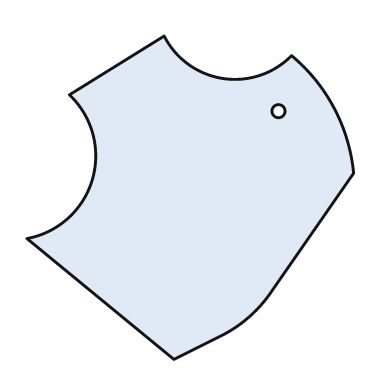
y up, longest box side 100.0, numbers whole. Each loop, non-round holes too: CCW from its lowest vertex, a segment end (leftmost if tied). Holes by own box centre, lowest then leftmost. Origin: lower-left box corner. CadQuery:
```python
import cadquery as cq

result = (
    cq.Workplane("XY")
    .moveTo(45.0, 0.0)
    .lineTo(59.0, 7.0)
    .threePointArc((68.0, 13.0), (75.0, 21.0))
    .lineTo(100.0, 57.0)
    .threePointArc((94.0, 77.0), (81.0, 93.0))
    .threePointArc((60.0, 86.0), (42.0, 99.0))
    .lineTo(13.0, 81.0)
    .threePointArc((20.0, 55.0), (0.0, 37.0))
    .close()
    .moveTo(77.0, 76.0)
    .circle(2.0)
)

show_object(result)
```